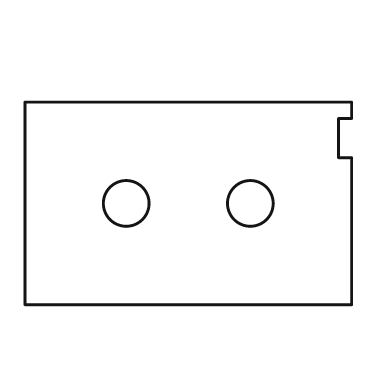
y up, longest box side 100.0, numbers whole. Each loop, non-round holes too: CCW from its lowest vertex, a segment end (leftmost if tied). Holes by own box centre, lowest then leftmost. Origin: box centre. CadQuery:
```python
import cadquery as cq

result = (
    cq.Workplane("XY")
    .moveTo(-50.0, -31.0)
    .lineTo(50.0, -31.0)
    .lineTo(50.0, 14.0)
    .lineTo(46.0, 14.0)
    .lineTo(46.0, 26.0)
    .lineTo(50.0, 26.0)
    .lineTo(50.0, 31.0)
    .lineTo(-50.0, 31.0)
    .close()
    .moveTo(-19.0, 0.0)
    .circle(7.0)
    .moveTo(19.0, 0.0)
    .circle(7.0)
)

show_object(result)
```